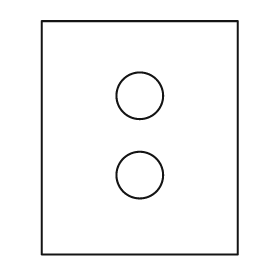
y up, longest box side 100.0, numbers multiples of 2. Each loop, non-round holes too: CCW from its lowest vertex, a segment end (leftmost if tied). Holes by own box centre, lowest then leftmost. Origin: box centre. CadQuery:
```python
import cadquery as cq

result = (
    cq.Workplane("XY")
    .moveTo(-42.0, -50.0)
    .lineTo(42.0, -50.0)
    .lineTo(42.0, 50.0)
    .lineTo(-42.0, 50.0)
    .close()
    .moveTo(0.0, -16.0)
    .circle(10.0)
    .moveTo(0.0, 18.0)
    .circle(10.0)
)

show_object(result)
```